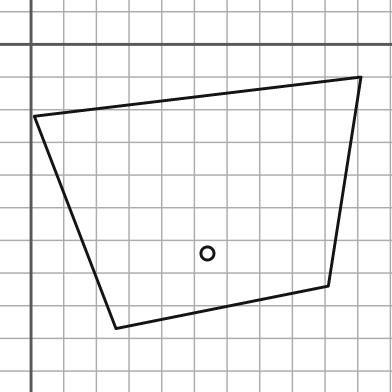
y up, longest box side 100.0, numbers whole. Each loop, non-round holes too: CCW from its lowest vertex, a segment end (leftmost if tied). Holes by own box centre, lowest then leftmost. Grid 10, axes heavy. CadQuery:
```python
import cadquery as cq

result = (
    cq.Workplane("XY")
    .moveTo(26.0, -87.0)
    .lineTo(91.0, -74.0)
    .lineTo(101.0, -10.0)
    .lineTo(1.0, -22.0)
    .close()
    .moveTo(54.0, -64.0)
    .circle(2.0)
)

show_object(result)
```